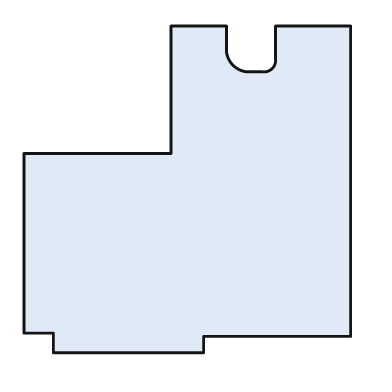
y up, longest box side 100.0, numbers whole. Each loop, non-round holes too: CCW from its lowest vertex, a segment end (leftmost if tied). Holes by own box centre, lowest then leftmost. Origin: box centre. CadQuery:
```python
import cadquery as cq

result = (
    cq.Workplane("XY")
    .moveTo(-41.0, -50.0)
    .lineTo(5.0, -50.0)
    .lineTo(5.0, -45.0)
    .lineTo(50.0, -45.0)
    .lineTo(50.0, 50.0)
    .lineTo(27.0, 50.0)
    .lineTo(27.0, 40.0)
    .threePointArc((26.0, 37.0), (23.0, 36.0))
    .lineTo(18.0, 36.0)
    .threePointArc((14.0, 38.0), (12.0, 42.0))
    .lineTo(12.0, 50.0)
    .lineTo(-5.0, 50.0)
    .lineTo(-5.0, 11.0)
    .lineTo(-50.0, 11.0)
    .lineTo(-50.0, -44.0)
    .lineTo(-41.0, -44.0)
    .close()
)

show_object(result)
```